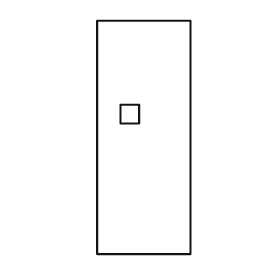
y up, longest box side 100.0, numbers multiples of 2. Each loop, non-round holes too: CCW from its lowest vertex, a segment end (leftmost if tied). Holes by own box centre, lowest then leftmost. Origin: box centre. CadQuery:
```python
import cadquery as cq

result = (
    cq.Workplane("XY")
    .moveTo(-20.0, -50.0)
    .lineTo(20.0, -50.0)
    .lineTo(20.0, 50.0)
    .lineTo(-20.0, 50.0)
    .close()
    .moveTo(-10.0, 6.0)
    .lineTo(-2.0, 6.0)
    .lineTo(-2.0, 14.0)
    .lineTo(-10.0, 14.0)
    .close()
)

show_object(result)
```